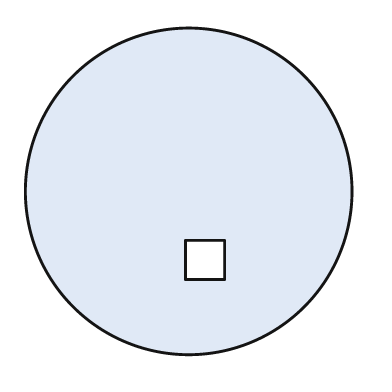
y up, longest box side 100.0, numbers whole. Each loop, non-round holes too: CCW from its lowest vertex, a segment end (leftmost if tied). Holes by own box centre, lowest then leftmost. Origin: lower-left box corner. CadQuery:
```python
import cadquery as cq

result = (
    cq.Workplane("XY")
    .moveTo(50.0, 50.0)
    .circle(50.0)
    .moveTo(49.0, 23.0)
    .lineTo(61.0, 23.0)
    .lineTo(61.0, 35.0)
    .lineTo(49.0, 35.0)
    .close()
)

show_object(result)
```